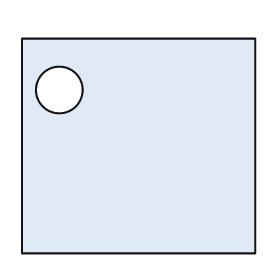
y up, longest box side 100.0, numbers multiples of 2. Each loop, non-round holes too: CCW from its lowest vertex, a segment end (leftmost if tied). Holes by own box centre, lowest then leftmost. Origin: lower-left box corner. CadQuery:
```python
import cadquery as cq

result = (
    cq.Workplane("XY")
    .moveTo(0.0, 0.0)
    .lineTo(100.0, 0.0)
    .lineTo(100.0, 92.0)
    .lineTo(0.0, 92.0)
    .close()
    .moveTo(16.0, 70.0)
    .circle(10.0)
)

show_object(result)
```